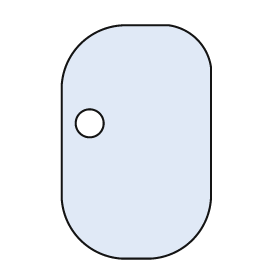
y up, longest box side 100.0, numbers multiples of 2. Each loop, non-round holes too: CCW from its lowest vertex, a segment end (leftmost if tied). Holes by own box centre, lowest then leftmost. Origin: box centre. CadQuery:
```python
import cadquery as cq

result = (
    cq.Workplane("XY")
    .moveTo(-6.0, -50.0)
    .lineTo(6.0, -50.0)
    .threePointArc((24.0, -42.0), (32.0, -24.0))
    .lineTo(32.0, 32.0)
    .threePointArc((26.0, 44.0), (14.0, 50.0))
    .lineTo(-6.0, 50.0)
    .threePointArc((-24.0, 42.0), (-32.0, 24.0))
    .lineTo(-32.0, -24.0)
    .threePointArc((-24.0, -42.0), (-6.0, -50.0))
    .close()
    .moveTo(-20.0, 8.0)
    .circle(6.0)
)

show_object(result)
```